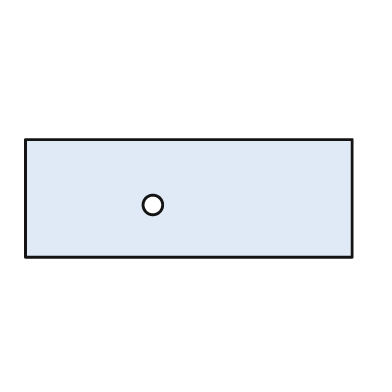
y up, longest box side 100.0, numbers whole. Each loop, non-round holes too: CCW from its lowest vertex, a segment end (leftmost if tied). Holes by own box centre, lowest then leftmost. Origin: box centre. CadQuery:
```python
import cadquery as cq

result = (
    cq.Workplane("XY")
    .moveTo(-50.0, -18.0)
    .lineTo(50.0, -18.0)
    .lineTo(50.0, 18.0)
    .lineTo(-50.0, 18.0)
    .close()
    .moveTo(-11.0, -2.0)
    .circle(3.0)
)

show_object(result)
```